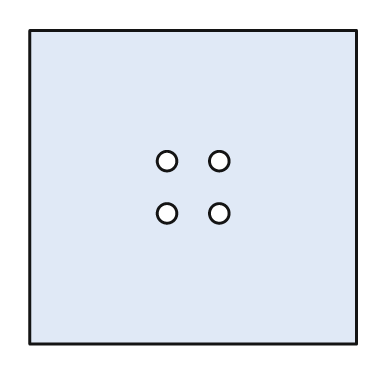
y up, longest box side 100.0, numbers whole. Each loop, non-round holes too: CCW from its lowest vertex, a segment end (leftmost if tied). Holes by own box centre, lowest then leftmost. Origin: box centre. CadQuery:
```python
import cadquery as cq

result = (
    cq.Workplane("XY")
    .moveTo(-50.0, -48.0)
    .lineTo(50.0, -48.0)
    .lineTo(50.0, 48.0)
    .lineTo(-50.0, 48.0)
    .close()
    .moveTo(-8.0, -8.0)
    .circle(3.0)
    .moveTo(8.0, -8.0)
    .circle(3.0)
    .moveTo(-8.0, 8.0)
    .circle(3.0)
    .moveTo(8.0, 8.0)
    .circle(3.0)
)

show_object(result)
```